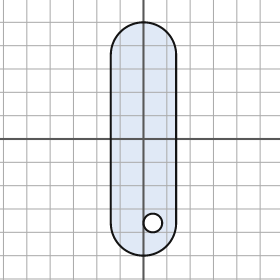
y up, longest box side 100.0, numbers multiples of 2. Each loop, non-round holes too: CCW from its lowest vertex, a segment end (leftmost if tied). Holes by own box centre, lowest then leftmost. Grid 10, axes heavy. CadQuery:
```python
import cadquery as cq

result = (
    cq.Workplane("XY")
    .moveTo(-14.0, -36.0)
    .threePointArc((0.0, -50.0), (14.0, -36.0))
    .lineTo(14.0, 36.0)
    .threePointArc((0.0, 50.0), (-14.0, 36.0))
    .close()
    .moveTo(4.0, -36.0)
    .circle(4.0)
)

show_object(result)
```